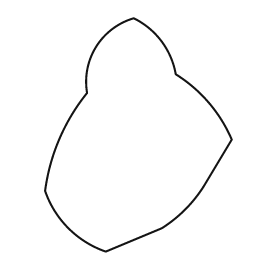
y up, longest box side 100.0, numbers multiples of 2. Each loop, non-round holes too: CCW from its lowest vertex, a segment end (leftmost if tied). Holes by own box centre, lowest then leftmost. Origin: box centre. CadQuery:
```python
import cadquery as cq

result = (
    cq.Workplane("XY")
    .moveTo(-14.0, -50.0)
    .lineTo(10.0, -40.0)
    .threePointArc((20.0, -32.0), (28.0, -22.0))
    .lineTo(40.0, -2.0)
    .threePointArc((30.0, 14.0), (16.0, 26.0))
    .threePointArc((10.0, 40.0), (-2.0, 50.0))
    .threePointArc((-18.0, 38.0), (-22.0, 18.0))
    .threePointArc((-34.0, -2.0), (-40.0, -24.0))
    .threePointArc((-30.0, -40.0), (-14.0, -50.0))
    .close()
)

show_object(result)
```